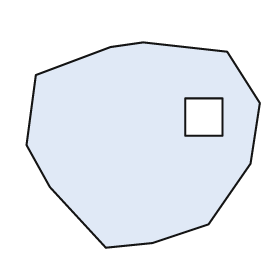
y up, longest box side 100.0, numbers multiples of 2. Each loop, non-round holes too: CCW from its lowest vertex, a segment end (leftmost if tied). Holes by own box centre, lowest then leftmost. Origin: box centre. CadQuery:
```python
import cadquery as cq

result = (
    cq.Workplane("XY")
    .moveTo(-16.0, -44.0)
    .lineTo(4.0, -42.0)
    .lineTo(28.0, -34.0)
    .lineTo(46.0, -8.0)
    .lineTo(50.0, 18.0)
    .lineTo(36.0, 40.0)
    .lineTo(0.0, 44.0)
    .lineTo(-14.0, 42.0)
    .lineTo(-46.0, 30.0)
    .lineTo(-50.0, 0.0)
    .lineTo(-40.0, -18.0)
    .close()
    .moveTo(18.0, 4.0)
    .lineTo(34.0, 4.0)
    .lineTo(34.0, 20.0)
    .lineTo(18.0, 20.0)
    .close()
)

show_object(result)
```